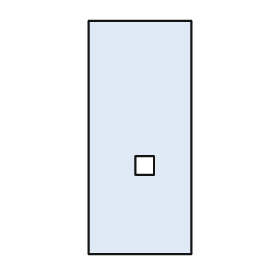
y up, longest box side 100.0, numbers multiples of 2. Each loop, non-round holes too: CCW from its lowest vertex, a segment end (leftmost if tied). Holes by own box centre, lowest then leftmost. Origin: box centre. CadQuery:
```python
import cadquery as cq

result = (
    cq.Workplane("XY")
    .moveTo(-22.0, -50.0)
    .lineTo(22.0, -50.0)
    .lineTo(22.0, 50.0)
    .lineTo(-22.0, 50.0)
    .close()
    .moveTo(-2.0, -16.0)
    .lineTo(6.0, -16.0)
    .lineTo(6.0, -8.0)
    .lineTo(-2.0, -8.0)
    .close()
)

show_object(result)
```